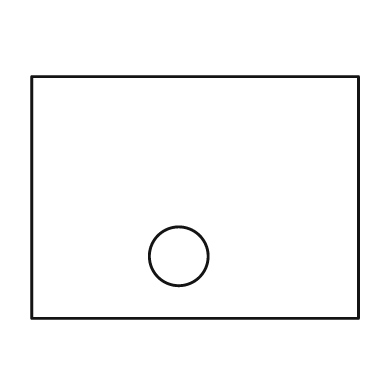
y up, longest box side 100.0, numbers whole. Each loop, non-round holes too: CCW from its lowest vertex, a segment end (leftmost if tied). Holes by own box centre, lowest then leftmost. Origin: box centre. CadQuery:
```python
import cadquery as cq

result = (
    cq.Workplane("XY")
    .moveTo(-50.0, -37.0)
    .lineTo(50.0, -37.0)
    .lineTo(50.0, 37.0)
    .lineTo(-50.0, 37.0)
    .close()
    .moveTo(-5.0, -18.0)
    .circle(9.0)
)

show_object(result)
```